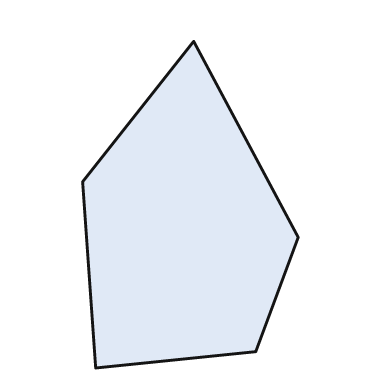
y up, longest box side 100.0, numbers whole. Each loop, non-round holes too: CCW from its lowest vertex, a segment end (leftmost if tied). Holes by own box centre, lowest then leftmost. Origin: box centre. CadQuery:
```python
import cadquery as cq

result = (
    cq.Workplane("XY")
    .moveTo(-29.0, -50.0)
    .lineTo(20.0, -45.0)
    .lineTo(33.0, -10.0)
    .lineTo(1.0, 50.0)
    .lineTo(-33.0, 7.0)
    .close()
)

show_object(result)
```